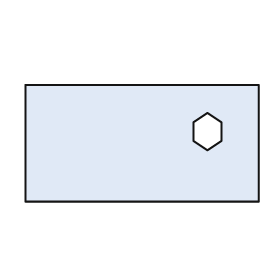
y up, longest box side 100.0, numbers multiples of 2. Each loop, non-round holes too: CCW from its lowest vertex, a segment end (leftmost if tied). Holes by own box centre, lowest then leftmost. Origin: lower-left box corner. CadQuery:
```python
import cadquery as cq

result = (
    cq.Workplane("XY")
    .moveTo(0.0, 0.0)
    .lineTo(100.0, 0.0)
    .lineTo(100.0, 50.0)
    .lineTo(0.0, 50.0)
    .close()
    .moveTo(78.0, 22.0)
    .lineTo(84.0, 26.0)
    .lineTo(84.0, 34.0)
    .lineTo(78.0, 38.0)
    .lineTo(72.0, 34.0)
    .lineTo(72.0, 26.0)
    .close()
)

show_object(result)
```